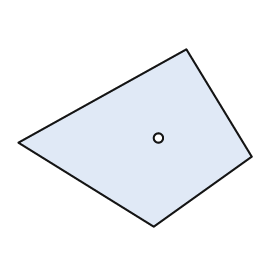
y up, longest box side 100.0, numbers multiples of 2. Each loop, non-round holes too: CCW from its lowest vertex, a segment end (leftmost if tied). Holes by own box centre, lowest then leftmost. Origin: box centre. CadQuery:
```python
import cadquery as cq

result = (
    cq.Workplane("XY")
    .moveTo(8.0, -38.0)
    .lineTo(50.0, -8.0)
    .lineTo(22.0, 38.0)
    .lineTo(-50.0, -2.0)
    .close()
    .moveTo(10.0, 0.0)
    .circle(2.0)
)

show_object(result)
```